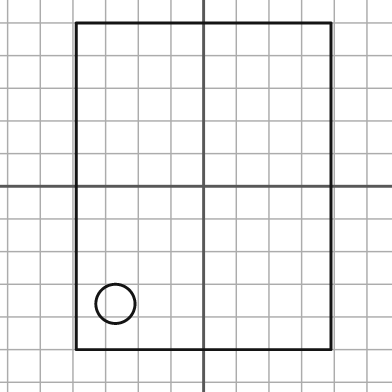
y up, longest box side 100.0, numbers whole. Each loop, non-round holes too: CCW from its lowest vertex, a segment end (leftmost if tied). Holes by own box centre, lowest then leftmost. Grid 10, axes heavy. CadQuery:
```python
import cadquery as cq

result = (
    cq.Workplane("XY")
    .moveTo(-39.0, -50.0)
    .lineTo(39.0, -50.0)
    .lineTo(39.0, 50.0)
    .lineTo(-39.0, 50.0)
    .close()
    .moveTo(-27.0, -36.0)
    .circle(6.0)
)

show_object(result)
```